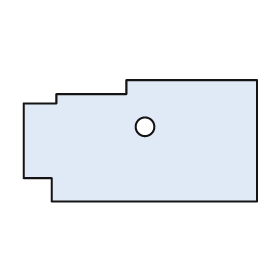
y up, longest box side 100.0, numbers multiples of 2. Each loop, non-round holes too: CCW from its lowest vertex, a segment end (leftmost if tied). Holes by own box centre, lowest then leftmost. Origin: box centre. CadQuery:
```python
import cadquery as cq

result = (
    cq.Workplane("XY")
    .moveTo(-38.0, -26.0)
    .lineTo(50.0, -26.0)
    .lineTo(50.0, 26.0)
    .lineTo(-6.0, 26.0)
    .lineTo(-6.0, 20.0)
    .lineTo(-36.0, 20.0)
    .lineTo(-36.0, 16.0)
    .lineTo(-50.0, 16.0)
    .lineTo(-50.0, -16.0)
    .lineTo(-38.0, -16.0)
    .close()
    .moveTo(2.0, 6.0)
    .circle(4.0)
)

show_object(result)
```